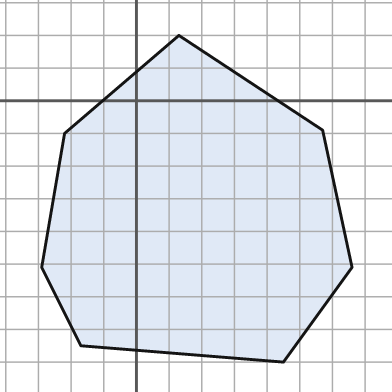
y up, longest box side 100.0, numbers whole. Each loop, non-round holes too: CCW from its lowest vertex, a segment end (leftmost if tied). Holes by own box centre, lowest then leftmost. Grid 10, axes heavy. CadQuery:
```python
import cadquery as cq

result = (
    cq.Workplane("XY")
    .moveTo(45.0, -80.0)
    .lineTo(66.0, -51.0)
    .lineTo(57.0, -9.0)
    .lineTo(13.0, 20.0)
    .lineTo(-22.0, -10.0)
    .lineTo(-29.0, -51.0)
    .lineTo(-17.0, -75.0)
    .close()
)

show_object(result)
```